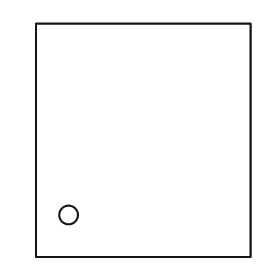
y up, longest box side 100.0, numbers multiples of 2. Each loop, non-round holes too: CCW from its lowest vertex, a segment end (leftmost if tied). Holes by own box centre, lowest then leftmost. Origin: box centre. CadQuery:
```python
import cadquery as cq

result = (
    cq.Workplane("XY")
    .moveTo(-46.0, -50.0)
    .lineTo(46.0, -50.0)
    .lineTo(46.0, 50.0)
    .lineTo(-46.0, 50.0)
    .close()
    .moveTo(-32.0, -32.0)
    .circle(4.0)
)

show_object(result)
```